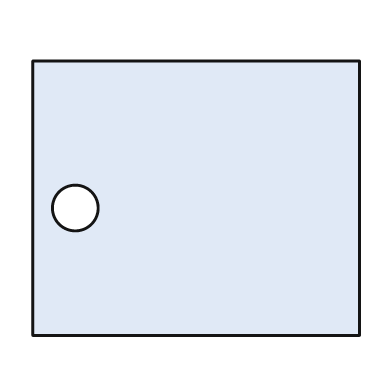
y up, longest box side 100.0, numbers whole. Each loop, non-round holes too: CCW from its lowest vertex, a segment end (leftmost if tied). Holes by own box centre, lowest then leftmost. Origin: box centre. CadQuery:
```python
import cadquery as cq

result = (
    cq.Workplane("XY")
    .moveTo(-50.0, -42.0)
    .lineTo(50.0, -42.0)
    .lineTo(50.0, 42.0)
    .lineTo(-50.0, 42.0)
    .close()
    .moveTo(-37.0, -3.0)
    .circle(7.0)
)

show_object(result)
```